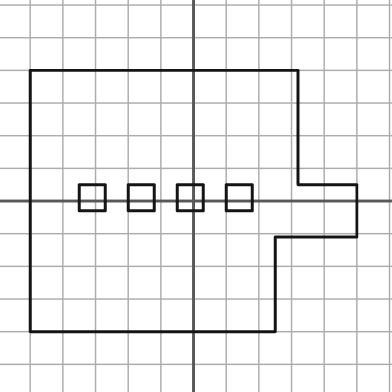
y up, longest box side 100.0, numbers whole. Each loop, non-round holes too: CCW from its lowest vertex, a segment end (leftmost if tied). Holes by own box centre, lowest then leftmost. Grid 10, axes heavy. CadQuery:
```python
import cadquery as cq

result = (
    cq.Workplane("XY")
    .moveTo(-50.0, -40.0)
    .lineTo(25.0, -40.0)
    .lineTo(25.0, -11.0)
    .lineTo(50.0, -11.0)
    .lineTo(50.0, 5.0)
    .lineTo(32.0, 5.0)
    .lineTo(32.0, 40.0)
    .lineTo(-50.0, 40.0)
    .close()
    .moveTo(-35.0, -3.0)
    .lineTo(-27.0, -3.0)
    .lineTo(-27.0, 5.0)
    .lineTo(-35.0, 5.0)
    .close()
    .moveTo(-20.0, -3.0)
    .lineTo(-12.0, -3.0)
    .lineTo(-12.0, 5.0)
    .lineTo(-20.0, 5.0)
    .close()
    .moveTo(-5.0, -3.0)
    .lineTo(3.0, -3.0)
    .lineTo(3.0, 5.0)
    .lineTo(-5.0, 5.0)
    .close()
    .moveTo(10.0, -3.0)
    .lineTo(18.0, -3.0)
    .lineTo(18.0, 5.0)
    .lineTo(10.0, 5.0)
    .close()
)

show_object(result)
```